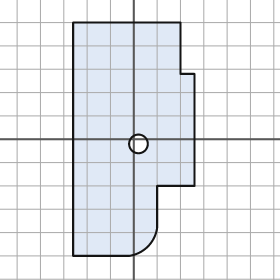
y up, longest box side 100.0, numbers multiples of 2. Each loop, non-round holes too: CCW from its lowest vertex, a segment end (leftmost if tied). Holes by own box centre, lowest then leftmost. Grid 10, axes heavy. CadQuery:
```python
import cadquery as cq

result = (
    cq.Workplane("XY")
    .moveTo(-26.0, -50.0)
    .lineTo(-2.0, -50.0)
    .threePointArc((6.0, -46.0), (10.0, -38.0))
    .lineTo(10.0, -20.0)
    .lineTo(26.0, -20.0)
    .lineTo(26.0, 28.0)
    .lineTo(20.0, 28.0)
    .lineTo(20.0, 50.0)
    .lineTo(-26.0, 50.0)
    .close()
    .moveTo(2.0, -2.0)
    .circle(4.0)
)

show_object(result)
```